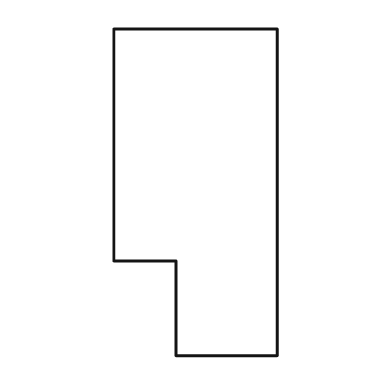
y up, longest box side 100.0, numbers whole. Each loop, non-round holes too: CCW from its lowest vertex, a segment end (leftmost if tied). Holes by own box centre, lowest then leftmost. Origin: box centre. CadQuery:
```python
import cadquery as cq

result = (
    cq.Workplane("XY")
    .moveTo(-6.0, -50.0)
    .lineTo(25.0, -50.0)
    .lineTo(25.0, 50.0)
    .lineTo(-25.0, 50.0)
    .lineTo(-25.0, -21.0)
    .lineTo(-6.0, -21.0)
    .close()
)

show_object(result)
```